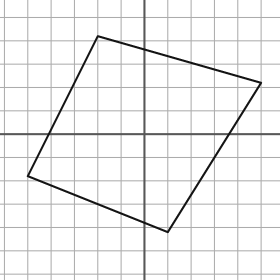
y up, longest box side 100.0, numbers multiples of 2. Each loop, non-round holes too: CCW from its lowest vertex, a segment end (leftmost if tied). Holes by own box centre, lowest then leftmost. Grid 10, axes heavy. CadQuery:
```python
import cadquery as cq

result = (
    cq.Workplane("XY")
    .moveTo(10.0, -42.0)
    .lineTo(50.0, 22.0)
    .lineTo(-20.0, 42.0)
    .lineTo(-50.0, -18.0)
    .close()
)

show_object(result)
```